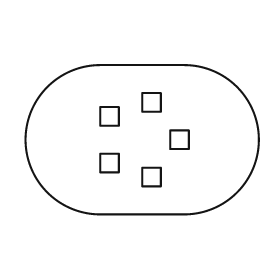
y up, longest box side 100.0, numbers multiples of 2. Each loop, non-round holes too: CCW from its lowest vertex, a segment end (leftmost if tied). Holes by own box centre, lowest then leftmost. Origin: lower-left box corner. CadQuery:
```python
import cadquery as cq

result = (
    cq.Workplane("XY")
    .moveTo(32.0, 0.0)
    .lineTo(68.0, 0.0)
    .threePointArc((100.0, 32.0), (68.0, 64.0))
    .lineTo(32.0, 64.0)
    .threePointArc((0.0, 32.0), (32.0, 0.0))
    .close()
    .moveTo(50.0, 12.0)
    .lineTo(58.0, 12.0)
    .lineTo(58.0, 20.0)
    .lineTo(50.0, 20.0)
    .close()
    .moveTo(32.0, 18.0)
    .lineTo(40.0, 18.0)
    .lineTo(40.0, 26.0)
    .lineTo(32.0, 26.0)
    .close()
    .moveTo(62.0, 28.0)
    .lineTo(70.0, 28.0)
    .lineTo(70.0, 36.0)
    .lineTo(62.0, 36.0)
    .close()
    .moveTo(32.0, 38.0)
    .lineTo(40.0, 38.0)
    .lineTo(40.0, 46.0)
    .lineTo(32.0, 46.0)
    .close()
    .moveTo(50.0, 44.0)
    .lineTo(58.0, 44.0)
    .lineTo(58.0, 52.0)
    .lineTo(50.0, 52.0)
    .close()
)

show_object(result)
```